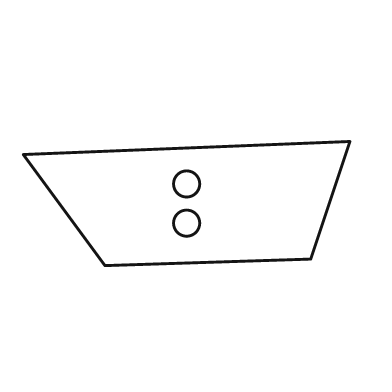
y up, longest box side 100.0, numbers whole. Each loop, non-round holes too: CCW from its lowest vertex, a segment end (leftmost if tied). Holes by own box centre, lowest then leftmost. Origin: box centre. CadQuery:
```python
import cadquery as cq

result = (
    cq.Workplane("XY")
    .moveTo(-25.0, -19.0)
    .lineTo(38.0, -17.0)
    .lineTo(50.0, 19.0)
    .lineTo(-50.0, 15.0)
    .close()
    .moveTo(0.0, -6.0)
    .circle(4.0)
    .moveTo(0.0, 6.0)
    .circle(4.0)
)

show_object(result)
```